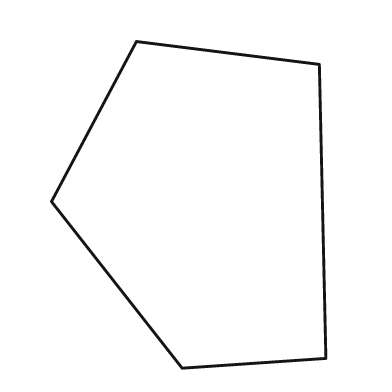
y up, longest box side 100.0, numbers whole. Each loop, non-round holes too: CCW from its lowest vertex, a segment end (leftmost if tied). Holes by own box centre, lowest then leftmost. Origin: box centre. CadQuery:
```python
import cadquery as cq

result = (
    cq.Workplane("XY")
    .moveTo(-2.0, -50.0)
    .lineTo(42.0, -47.0)
    .lineTo(40.0, 43.0)
    .lineTo(-16.0, 50.0)
    .lineTo(-42.0, 1.0)
    .close()
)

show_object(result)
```